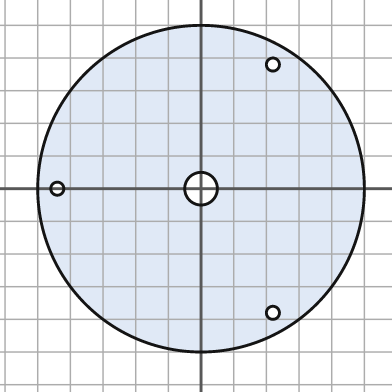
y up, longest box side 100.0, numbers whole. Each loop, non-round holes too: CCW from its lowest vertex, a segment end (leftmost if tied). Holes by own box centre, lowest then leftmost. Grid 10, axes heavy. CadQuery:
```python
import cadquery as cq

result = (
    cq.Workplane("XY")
    .moveTo(0.0, 0.0)
    .circle(50.0)
    .moveTo(22.0, -38.0)
    .circle(2.0)
    .moveTo(-44.0, 0.0)
    .circle(2.0)
    .moveTo(0.0, 0.0)
    .circle(5.0)
    .moveTo(22.0, 38.0)
    .circle(2.0)
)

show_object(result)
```